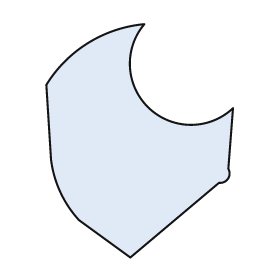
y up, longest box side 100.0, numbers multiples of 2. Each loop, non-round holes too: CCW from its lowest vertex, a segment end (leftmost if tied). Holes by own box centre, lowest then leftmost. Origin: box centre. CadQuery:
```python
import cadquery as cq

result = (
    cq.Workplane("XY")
    .moveTo(-4.0, -50.0)
    .lineTo(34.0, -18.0)
    .threePointArc((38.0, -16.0), (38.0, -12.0))
    .lineTo(40.0, 14.0)
    .threePointArc((4.0, 14.0), (2.0, 50.0))
    .threePointArc((-22.0, 42.0), (-40.0, 24.0))
    .lineTo(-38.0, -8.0)
    .threePointArc((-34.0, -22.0), (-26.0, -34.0))
    .close()
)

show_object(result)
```